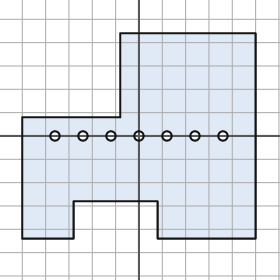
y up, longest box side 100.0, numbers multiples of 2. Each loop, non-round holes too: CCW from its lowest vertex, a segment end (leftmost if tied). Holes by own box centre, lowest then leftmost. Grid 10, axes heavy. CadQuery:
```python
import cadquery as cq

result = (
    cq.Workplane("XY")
    .moveTo(-50.0, -44.0)
    .lineTo(-28.0, -44.0)
    .lineTo(-28.0, -28.0)
    .lineTo(8.0, -28.0)
    .lineTo(8.0, -44.0)
    .lineTo(50.0, -44.0)
    .lineTo(50.0, 44.0)
    .lineTo(-8.0, 44.0)
    .lineTo(-8.0, 8.0)
    .lineTo(-50.0, 8.0)
    .close()
    .moveTo(-36.0, 0.0)
    .circle(2.0)
    .moveTo(-24.0, 0.0)
    .circle(2.0)
    .moveTo(-12.0, 0.0)
    .circle(2.0)
    .moveTo(0.0, 0.0)
    .circle(2.0)
    .moveTo(12.0, 0.0)
    .circle(2.0)
    .moveTo(24.0, 0.0)
    .circle(2.0)
    .moveTo(36.0, 0.0)
    .circle(2.0)
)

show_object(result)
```